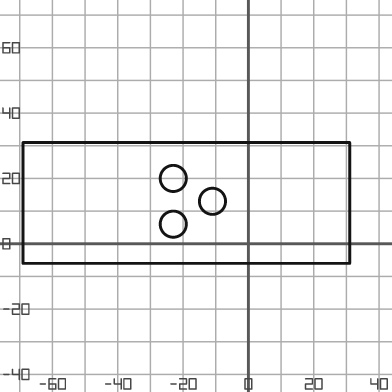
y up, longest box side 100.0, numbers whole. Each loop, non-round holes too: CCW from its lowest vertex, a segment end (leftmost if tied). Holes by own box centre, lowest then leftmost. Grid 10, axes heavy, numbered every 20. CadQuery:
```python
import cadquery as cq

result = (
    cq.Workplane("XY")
    .moveTo(-69.0, -6.0)
    .lineTo(31.0, -6.0)
    .lineTo(31.0, 31.0)
    .lineTo(-69.0, 31.0)
    .close()
    .moveTo(-23.0, 6.0)
    .circle(4.0)
    .moveTo(-11.0, 13.0)
    .circle(4.0)
    .moveTo(-23.0, 20.0)
    .circle(4.0)
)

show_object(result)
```